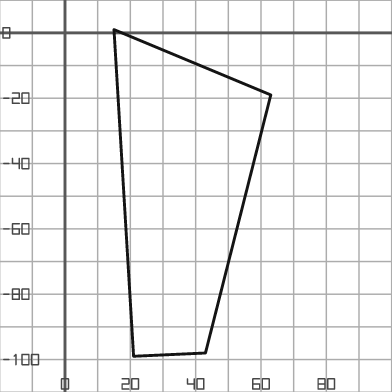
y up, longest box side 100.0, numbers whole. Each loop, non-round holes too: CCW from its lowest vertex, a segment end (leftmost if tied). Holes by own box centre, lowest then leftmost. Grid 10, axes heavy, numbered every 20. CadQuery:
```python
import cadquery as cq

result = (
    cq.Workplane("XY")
    .moveTo(21.0, -99.0)
    .lineTo(43.0, -98.0)
    .lineTo(63.0, -19.0)
    .lineTo(15.0, 1.0)
    .close()
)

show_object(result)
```